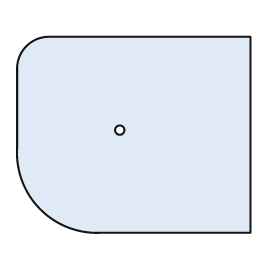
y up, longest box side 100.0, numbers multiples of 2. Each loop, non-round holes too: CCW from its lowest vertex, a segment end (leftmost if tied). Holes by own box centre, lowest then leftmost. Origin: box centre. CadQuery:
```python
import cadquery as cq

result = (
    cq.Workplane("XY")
    .moveTo(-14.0, -42.0)
    .lineTo(50.0, -42.0)
    .lineTo(50.0, 42.0)
    .lineTo(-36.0, 42.0)
    .threePointArc((-46.0, 38.0), (-50.0, 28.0))
    .lineTo(-50.0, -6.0)
    .threePointArc((-40.0, -32.0), (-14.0, -42.0))
    .close()
    .moveTo(-6.0, 2.0)
    .circle(2.0)
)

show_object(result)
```